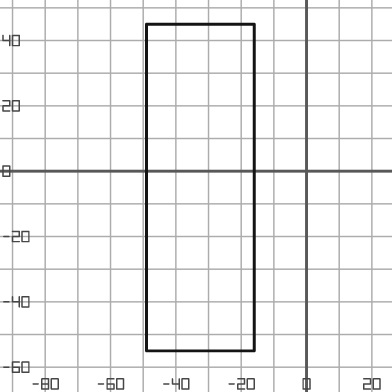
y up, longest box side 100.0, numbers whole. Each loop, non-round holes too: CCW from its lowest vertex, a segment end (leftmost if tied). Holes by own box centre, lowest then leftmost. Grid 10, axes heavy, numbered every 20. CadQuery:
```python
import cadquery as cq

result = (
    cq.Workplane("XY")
    .moveTo(-49.0, -55.0)
    .lineTo(-16.0, -55.0)
    .lineTo(-16.0, 45.0)
    .lineTo(-49.0, 45.0)
    .close()
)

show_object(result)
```